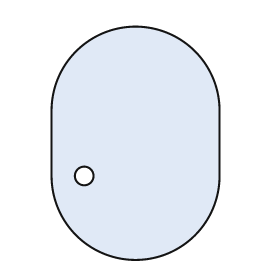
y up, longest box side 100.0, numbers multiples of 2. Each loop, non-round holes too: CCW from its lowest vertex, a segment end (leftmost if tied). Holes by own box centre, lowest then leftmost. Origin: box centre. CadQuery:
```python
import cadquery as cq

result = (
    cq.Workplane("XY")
    .moveTo(-36.0, -14.0)
    .threePointArc((0.0, -50.0), (36.0, -14.0))
    .lineTo(36.0, 14.0)
    .threePointArc((0.0, 50.0), (-36.0, 14.0))
    .close()
    .moveTo(-22.0, -14.0)
    .circle(4.0)
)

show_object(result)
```